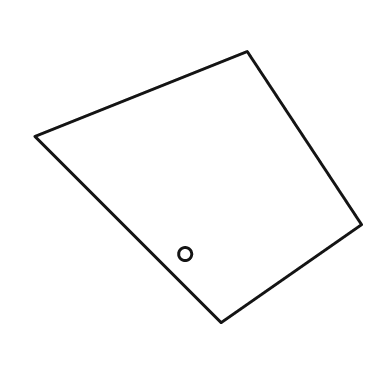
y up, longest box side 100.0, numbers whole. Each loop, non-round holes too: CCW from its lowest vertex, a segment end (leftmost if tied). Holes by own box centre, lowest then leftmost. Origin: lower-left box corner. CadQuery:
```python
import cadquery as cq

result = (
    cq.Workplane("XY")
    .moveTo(57.0, 0.0)
    .lineTo(100.0, 30.0)
    .lineTo(65.0, 83.0)
    .lineTo(0.0, 57.0)
    .close()
    .moveTo(46.0, 21.0)
    .circle(2.0)
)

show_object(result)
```